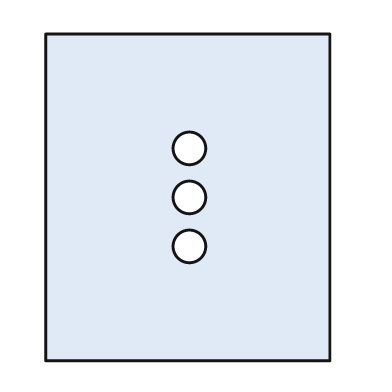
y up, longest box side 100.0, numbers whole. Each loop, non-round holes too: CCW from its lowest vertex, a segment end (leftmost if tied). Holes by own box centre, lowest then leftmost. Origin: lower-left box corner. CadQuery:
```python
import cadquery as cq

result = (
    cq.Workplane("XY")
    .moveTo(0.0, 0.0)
    .lineTo(87.0, 0.0)
    .lineTo(87.0, 100.0)
    .lineTo(0.0, 100.0)
    .close()
    .moveTo(44.0, 35.0)
    .circle(5.0)
    .moveTo(44.0, 50.0)
    .circle(5.0)
    .moveTo(44.0, 65.0)
    .circle(5.0)
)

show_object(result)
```